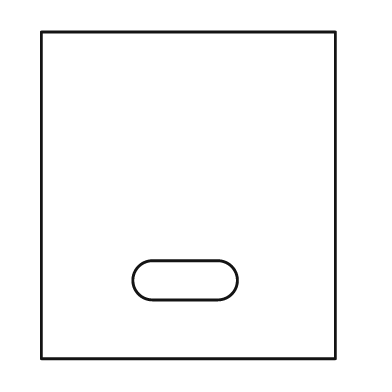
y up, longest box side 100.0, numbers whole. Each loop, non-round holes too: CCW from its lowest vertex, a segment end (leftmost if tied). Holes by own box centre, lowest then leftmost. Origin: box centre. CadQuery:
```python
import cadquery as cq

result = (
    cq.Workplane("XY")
    .moveTo(-45.0, -50.0)
    .lineTo(45.0, -50.0)
    .lineTo(45.0, 50.0)
    .lineTo(-45.0, 50.0)
    .close()
    .moveTo(-11.0, -32.0)
    .lineTo(9.0, -32.0)
    .threePointArc((15.0, -26.0), (9.0, -20.0))
    .lineTo(-11.0, -20.0)
    .threePointArc((-17.0, -26.0), (-11.0, -32.0))
    .close()
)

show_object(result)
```